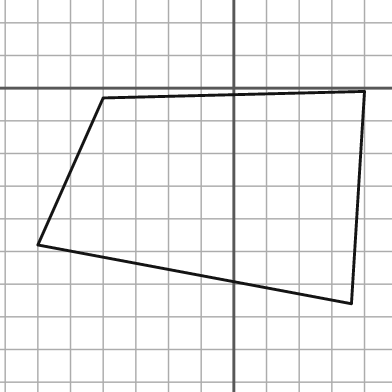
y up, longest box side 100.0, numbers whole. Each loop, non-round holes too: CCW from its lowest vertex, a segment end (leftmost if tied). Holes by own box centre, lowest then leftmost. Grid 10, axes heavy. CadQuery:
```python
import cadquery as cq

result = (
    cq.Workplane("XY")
    .moveTo(36.0, -66.0)
    .lineTo(40.0, -1.0)
    .lineTo(-40.0, -3.0)
    .lineTo(-60.0, -48.0)
    .close()
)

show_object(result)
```